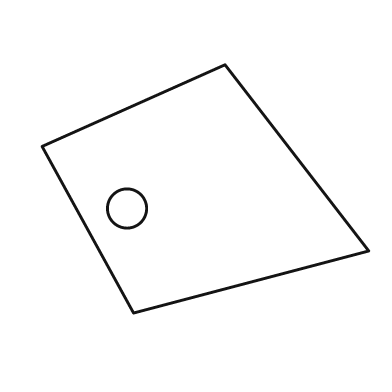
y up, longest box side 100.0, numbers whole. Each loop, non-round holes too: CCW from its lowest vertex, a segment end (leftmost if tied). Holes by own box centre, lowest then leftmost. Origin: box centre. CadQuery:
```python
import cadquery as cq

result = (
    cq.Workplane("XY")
    .moveTo(-22.0, -38.0)
    .lineTo(50.0, -19.0)
    .lineTo(6.0, 38.0)
    .lineTo(-50.0, 13.0)
    .close()
    .moveTo(-24.0, -6.0)
    .circle(6.0)
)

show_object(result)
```